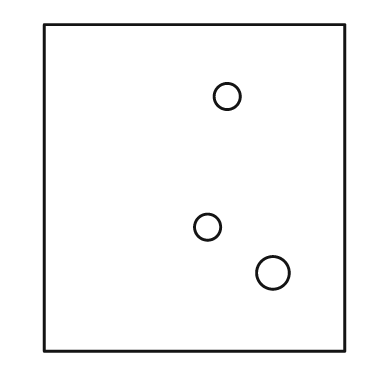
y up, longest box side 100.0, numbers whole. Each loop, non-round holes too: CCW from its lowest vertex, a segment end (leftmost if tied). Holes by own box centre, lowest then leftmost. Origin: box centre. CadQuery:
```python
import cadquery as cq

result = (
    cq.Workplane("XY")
    .moveTo(-46.0, -50.0)
    .lineTo(46.0, -50.0)
    .lineTo(46.0, 50.0)
    .lineTo(-46.0, 50.0)
    .close()
    .moveTo(24.0, -26.0)
    .circle(5.0)
    .moveTo(4.0, -12.0)
    .circle(4.0)
    .moveTo(10.0, 28.0)
    .circle(4.0)
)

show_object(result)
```